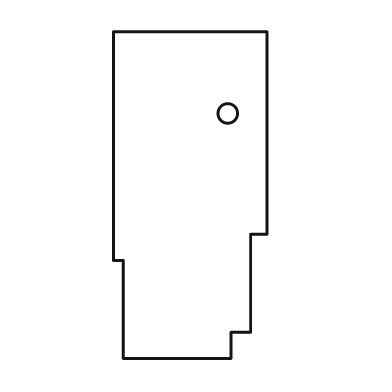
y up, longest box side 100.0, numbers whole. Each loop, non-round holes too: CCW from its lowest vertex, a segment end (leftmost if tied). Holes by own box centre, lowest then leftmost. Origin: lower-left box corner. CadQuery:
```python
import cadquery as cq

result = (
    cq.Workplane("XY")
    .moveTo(3.0, 0.0)
    .lineTo(36.0, 0.0)
    .lineTo(36.0, 8.0)
    .lineTo(42.0, 8.0)
    .lineTo(42.0, 38.0)
    .lineTo(47.0, 38.0)
    .lineTo(47.0, 100.0)
    .lineTo(0.0, 100.0)
    .lineTo(0.0, 30.0)
    .lineTo(3.0, 30.0)
    .close()
    .moveTo(35.0, 75.0)
    .circle(3.0)
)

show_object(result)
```